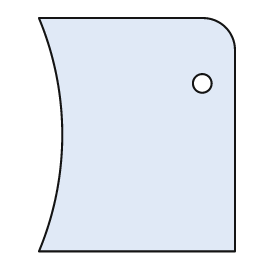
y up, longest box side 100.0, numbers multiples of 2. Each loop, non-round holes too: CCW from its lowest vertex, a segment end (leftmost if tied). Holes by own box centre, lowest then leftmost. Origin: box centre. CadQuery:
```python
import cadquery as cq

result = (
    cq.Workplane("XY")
    .moveTo(-42.0, -50.0)
    .lineTo(42.0, -50.0)
    .lineTo(42.0, 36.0)
    .threePointArc((38.0, 46.0), (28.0, 50.0))
    .lineTo(-42.0, 50.0)
    .threePointArc((-32.0, 0.0), (-42.0, -50.0))
    .close()
    .moveTo(28.0, 22.0)
    .circle(4.0)
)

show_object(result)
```